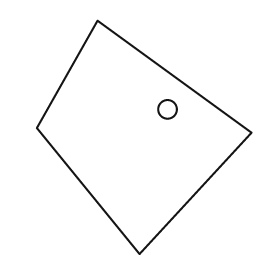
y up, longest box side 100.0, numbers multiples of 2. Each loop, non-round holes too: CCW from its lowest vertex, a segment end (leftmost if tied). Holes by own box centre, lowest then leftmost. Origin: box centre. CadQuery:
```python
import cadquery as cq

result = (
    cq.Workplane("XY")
    .moveTo(-2.0, -50.0)
    .lineTo(46.0, 2.0)
    .lineTo(-20.0, 50.0)
    .lineTo(-46.0, 4.0)
    .close()
    .moveTo(10.0, 12.0)
    .circle(4.0)
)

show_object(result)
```